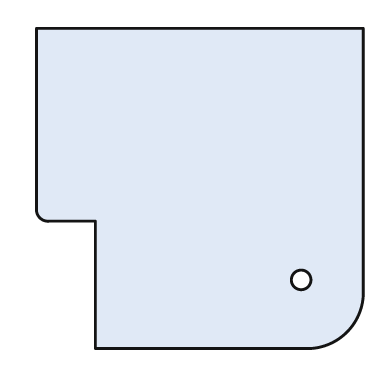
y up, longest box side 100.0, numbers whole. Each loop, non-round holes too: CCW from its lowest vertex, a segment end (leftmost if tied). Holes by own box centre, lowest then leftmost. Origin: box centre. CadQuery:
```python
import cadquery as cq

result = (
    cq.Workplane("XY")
    .moveTo(-32.0, -49.0)
    .lineTo(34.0, -49.0)
    .threePointArc((45.0, -44.0), (50.0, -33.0))
    .lineTo(50.0, 49.0)
    .lineTo(-50.0, 49.0)
    .lineTo(-50.0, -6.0)
    .threePointArc((-49.0, -9.0), (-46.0, -10.0))
    .lineTo(-32.0, -10.0)
    .close()
    .moveTo(31.0, -28.0)
    .circle(3.0)
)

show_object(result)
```